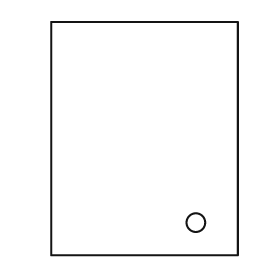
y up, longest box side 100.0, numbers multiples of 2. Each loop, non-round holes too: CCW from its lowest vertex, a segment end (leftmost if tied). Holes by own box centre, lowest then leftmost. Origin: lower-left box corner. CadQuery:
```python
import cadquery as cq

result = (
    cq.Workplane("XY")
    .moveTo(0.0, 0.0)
    .lineTo(80.0, 0.0)
    .lineTo(80.0, 100.0)
    .lineTo(0.0, 100.0)
    .close()
    .moveTo(62.0, 14.0)
    .circle(4.0)
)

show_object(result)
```